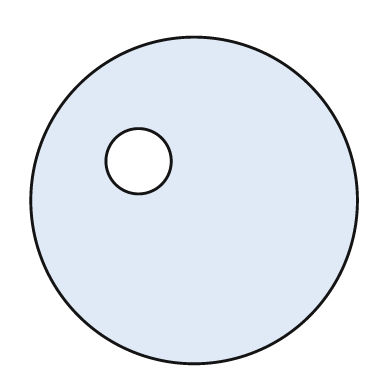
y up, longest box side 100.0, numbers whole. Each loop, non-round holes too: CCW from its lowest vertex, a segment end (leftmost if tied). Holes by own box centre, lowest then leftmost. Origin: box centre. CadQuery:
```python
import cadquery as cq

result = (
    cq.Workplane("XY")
    .moveTo(0.0, 0.0)
    .circle(50.0)
    .moveTo(-17.0, 12.0)
    .circle(10.0)
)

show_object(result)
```